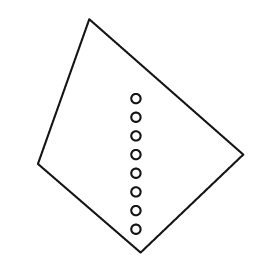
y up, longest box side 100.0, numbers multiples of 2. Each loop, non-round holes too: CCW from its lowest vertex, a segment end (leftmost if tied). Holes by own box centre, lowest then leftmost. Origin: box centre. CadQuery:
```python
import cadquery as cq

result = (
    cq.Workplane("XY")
    .moveTo(0.0, -50.0)
    .lineTo(44.0, -8.0)
    .lineTo(-22.0, 50.0)
    .lineTo(-44.0, -12.0)
    .close()
    .moveTo(-2.0, -40.0)
    .circle(2.0)
    .moveTo(-2.0, -32.0)
    .circle(2.0)
    .moveTo(-2.0, -24.0)
    .circle(2.0)
    .moveTo(-2.0, -16.0)
    .circle(2.0)
    .moveTo(-2.0, -8.0)
    .circle(2.0)
    .moveTo(-2.0, 0.0)
    .circle(2.0)
    .moveTo(-2.0, 8.0)
    .circle(2.0)
    .moveTo(-2.0, 16.0)
    .circle(2.0)
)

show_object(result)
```